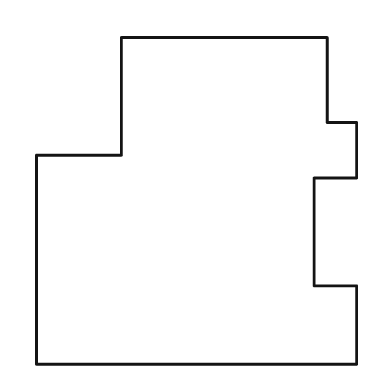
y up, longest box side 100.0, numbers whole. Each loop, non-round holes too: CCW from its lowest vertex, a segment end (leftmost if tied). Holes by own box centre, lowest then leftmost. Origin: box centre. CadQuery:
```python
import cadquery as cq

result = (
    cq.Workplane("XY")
    .moveTo(-49.0, -50.0)
    .lineTo(49.0, -50.0)
    .lineTo(49.0, -26.0)
    .lineTo(36.0, -26.0)
    .lineTo(36.0, 7.0)
    .lineTo(49.0, 7.0)
    .lineTo(49.0, 24.0)
    .lineTo(40.0, 24.0)
    .lineTo(40.0, 50.0)
    .lineTo(-23.0, 50.0)
    .lineTo(-23.0, 14.0)
    .lineTo(-49.0, 14.0)
    .close()
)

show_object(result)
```